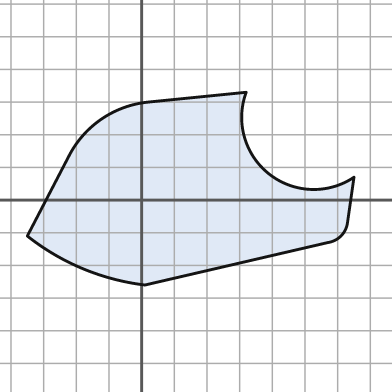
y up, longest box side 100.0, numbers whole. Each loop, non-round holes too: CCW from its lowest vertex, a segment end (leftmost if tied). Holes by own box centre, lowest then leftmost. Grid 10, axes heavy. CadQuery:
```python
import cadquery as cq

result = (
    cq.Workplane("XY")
    .moveTo(1.0, -26.0)
    .lineTo(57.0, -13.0)
    .threePointArc((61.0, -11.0), (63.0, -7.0))
    .lineTo(65.0, 7.0)
    .threePointArc((39.0, 8.0), (32.0, 33.0))
    .lineTo(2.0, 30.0)
    .threePointArc((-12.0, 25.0), (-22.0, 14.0))
    .lineTo(-35.0, -11.0)
    .threePointArc((-18.0, -21.0), (1.0, -26.0))
    .close()
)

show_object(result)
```